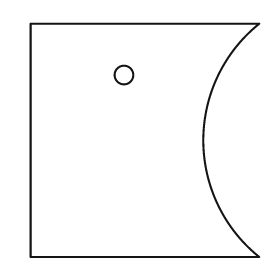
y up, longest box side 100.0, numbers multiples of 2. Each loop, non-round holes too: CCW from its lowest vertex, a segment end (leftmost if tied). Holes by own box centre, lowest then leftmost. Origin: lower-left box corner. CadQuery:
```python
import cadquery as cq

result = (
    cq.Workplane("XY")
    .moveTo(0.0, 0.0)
    .lineTo(98.0, 0.0)
    .threePointArc((74.0, 50.0), (98.0, 100.0))
    .lineTo(0.0, 100.0)
    .close()
    .moveTo(40.0, 78.0)
    .circle(4.0)
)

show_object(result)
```